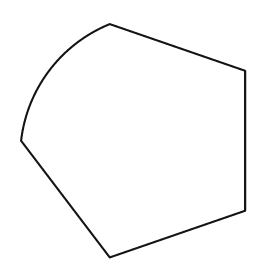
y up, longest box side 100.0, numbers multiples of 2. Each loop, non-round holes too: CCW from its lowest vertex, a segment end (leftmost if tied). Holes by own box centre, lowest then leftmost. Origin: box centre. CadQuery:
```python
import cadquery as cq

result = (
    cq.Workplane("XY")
    .moveTo(-10.0, -50.0)
    .lineTo(48.0, -30.0)
    .lineTo(48.0, 30.0)
    .lineTo(-10.0, 50.0)
    .threePointArc((-36.0, 30.0), (-48.0, 0.0))
    .close()
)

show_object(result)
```